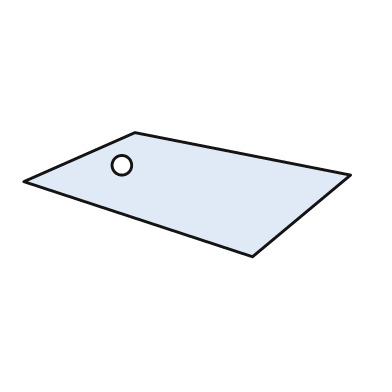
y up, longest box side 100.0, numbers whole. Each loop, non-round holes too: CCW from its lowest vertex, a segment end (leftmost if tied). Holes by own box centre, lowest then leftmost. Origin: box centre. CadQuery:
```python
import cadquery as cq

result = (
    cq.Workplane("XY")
    .moveTo(20.0, -19.0)
    .lineTo(50.0, 6.0)
    .lineTo(-16.0, 19.0)
    .lineTo(-50.0, 4.0)
    .close()
    .moveTo(-20.0, 9.0)
    .circle(3.0)
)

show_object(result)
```